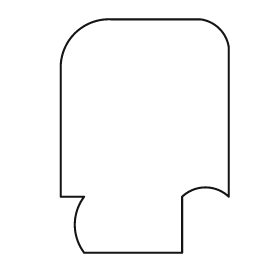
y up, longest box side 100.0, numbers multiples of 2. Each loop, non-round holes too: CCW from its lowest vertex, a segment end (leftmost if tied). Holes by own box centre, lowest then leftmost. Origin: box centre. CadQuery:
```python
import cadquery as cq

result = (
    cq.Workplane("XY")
    .moveTo(-26.0, -50.0)
    .lineTo(16.0, -50.0)
    .lineTo(16.0, -26.0)
    .threePointArc((26.0, -22.0), (36.0, -26.0))
    .lineTo(36.0, 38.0)
    .threePointArc((32.0, 46.0), (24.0, 50.0))
    .lineTo(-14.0, 50.0)
    .threePointArc((-30.0, 44.0), (-36.0, 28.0))
    .lineTo(-36.0, -26.0)
    .lineTo(-26.0, -26.0)
    .threePointArc((-30.0, -38.0), (-26.0, -50.0))
    .close()
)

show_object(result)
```